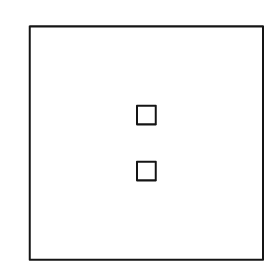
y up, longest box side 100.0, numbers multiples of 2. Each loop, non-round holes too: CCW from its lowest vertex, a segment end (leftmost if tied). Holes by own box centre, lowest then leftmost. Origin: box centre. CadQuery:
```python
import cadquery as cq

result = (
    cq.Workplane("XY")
    .moveTo(-50.0, -50.0)
    .lineTo(50.0, -50.0)
    .lineTo(50.0, 50.0)
    .lineTo(-50.0, 50.0)
    .close()
    .moveTo(-4.0, -16.0)
    .lineTo(4.0, -16.0)
    .lineTo(4.0, -8.0)
    .lineTo(-4.0, -8.0)
    .close()
    .moveTo(-4.0, 8.0)
    .lineTo(4.0, 8.0)
    .lineTo(4.0, 16.0)
    .lineTo(-4.0, 16.0)
    .close()
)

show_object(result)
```